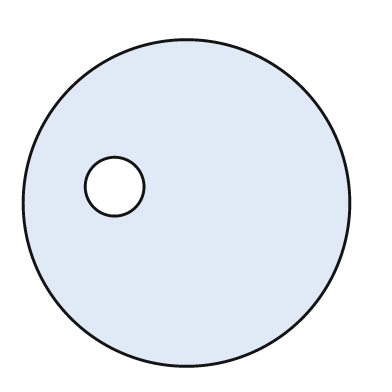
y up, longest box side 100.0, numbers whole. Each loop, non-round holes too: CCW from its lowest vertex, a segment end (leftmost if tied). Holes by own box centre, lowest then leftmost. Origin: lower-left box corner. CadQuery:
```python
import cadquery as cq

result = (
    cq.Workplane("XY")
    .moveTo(50.0, 50.0)
    .circle(50.0)
    .moveTo(28.0, 55.0)
    .circle(9.0)
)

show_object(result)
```